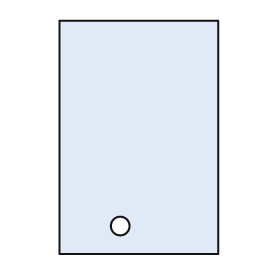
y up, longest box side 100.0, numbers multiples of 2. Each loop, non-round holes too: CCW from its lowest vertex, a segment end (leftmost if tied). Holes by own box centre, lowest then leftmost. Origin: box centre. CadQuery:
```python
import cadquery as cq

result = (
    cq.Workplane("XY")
    .moveTo(-34.0, -50.0)
    .lineTo(34.0, -50.0)
    .lineTo(34.0, 50.0)
    .lineTo(-34.0, 50.0)
    .close()
    .moveTo(-8.0, -38.0)
    .circle(4.0)
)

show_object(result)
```